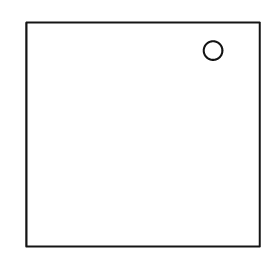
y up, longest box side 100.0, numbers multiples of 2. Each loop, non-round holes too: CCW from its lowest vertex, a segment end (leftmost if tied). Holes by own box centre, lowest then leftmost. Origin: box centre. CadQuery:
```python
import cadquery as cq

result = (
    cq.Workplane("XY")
    .moveTo(-50.0, -48.0)
    .lineTo(50.0, -48.0)
    .lineTo(50.0, 48.0)
    .lineTo(-50.0, 48.0)
    .close()
    .moveTo(30.0, 36.0)
    .circle(4.0)
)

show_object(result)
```